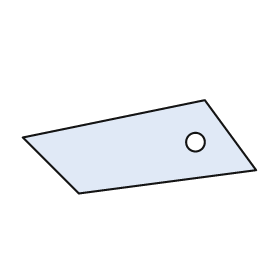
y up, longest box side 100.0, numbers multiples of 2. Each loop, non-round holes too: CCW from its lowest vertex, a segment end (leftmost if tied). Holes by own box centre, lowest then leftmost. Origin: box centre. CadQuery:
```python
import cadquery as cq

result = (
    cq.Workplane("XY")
    .moveTo(-26.0, -20.0)
    .lineTo(50.0, -10.0)
    .lineTo(28.0, 20.0)
    .lineTo(-50.0, 4.0)
    .close()
    .moveTo(24.0, 2.0)
    .circle(4.0)
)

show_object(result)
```